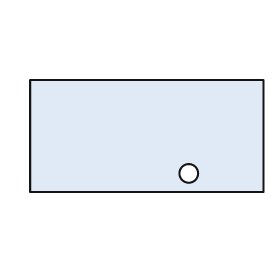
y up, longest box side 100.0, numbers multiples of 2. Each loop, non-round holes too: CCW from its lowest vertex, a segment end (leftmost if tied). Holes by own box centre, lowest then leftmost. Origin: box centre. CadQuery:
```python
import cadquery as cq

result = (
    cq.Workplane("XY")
    .moveTo(-50.0, -24.0)
    .lineTo(50.0, -24.0)
    .lineTo(50.0, 24.0)
    .lineTo(-50.0, 24.0)
    .close()
    .moveTo(18.0, -16.0)
    .circle(4.0)
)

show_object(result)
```